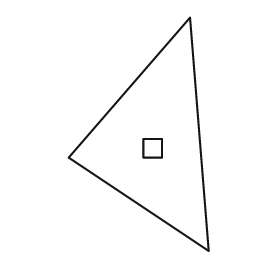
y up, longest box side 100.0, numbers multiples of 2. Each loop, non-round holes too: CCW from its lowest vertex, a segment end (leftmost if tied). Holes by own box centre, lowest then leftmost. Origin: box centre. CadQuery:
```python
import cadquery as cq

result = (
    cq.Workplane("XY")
    .moveTo(30.0, -50.0)
    .lineTo(22.0, 50.0)
    .lineTo(-30.0, -10.0)
    .close()
    .moveTo(2.0, -10.0)
    .lineTo(10.0, -10.0)
    .lineTo(10.0, -2.0)
    .lineTo(2.0, -2.0)
    .close()
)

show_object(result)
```